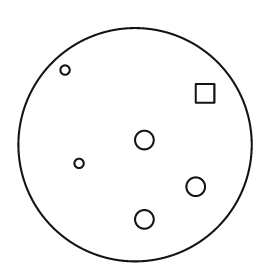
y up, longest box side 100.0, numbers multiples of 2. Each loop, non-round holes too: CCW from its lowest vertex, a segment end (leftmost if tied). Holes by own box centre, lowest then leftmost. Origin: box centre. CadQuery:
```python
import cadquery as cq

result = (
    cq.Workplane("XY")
    .moveTo(0.0, 0.0)
    .circle(50.0)
    .moveTo(4.0, -32.0)
    .circle(4.0)
    .moveTo(26.0, -18.0)
    .circle(4.0)
    .moveTo(-24.0, -8.0)
    .circle(2.0)
    .moveTo(4.0, 2.0)
    .circle(4.0)
    .moveTo(26.0, 18.0)
    .lineTo(34.0, 18.0)
    .lineTo(34.0, 26.0)
    .lineTo(26.0, 26.0)
    .close()
    .moveTo(-30.0, 32.0)
    .circle(2.0)
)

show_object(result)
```